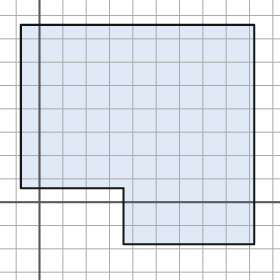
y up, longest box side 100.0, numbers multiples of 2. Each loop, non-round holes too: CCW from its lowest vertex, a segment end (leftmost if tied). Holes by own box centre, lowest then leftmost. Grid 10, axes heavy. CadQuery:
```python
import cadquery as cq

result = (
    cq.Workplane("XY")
    .moveTo(36.0, -18.0)
    .lineTo(92.0, -18.0)
    .lineTo(92.0, 76.0)
    .lineTo(-8.0, 76.0)
    .lineTo(-8.0, 6.0)
    .lineTo(36.0, 6.0)
    .close()
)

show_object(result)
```